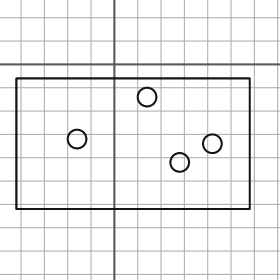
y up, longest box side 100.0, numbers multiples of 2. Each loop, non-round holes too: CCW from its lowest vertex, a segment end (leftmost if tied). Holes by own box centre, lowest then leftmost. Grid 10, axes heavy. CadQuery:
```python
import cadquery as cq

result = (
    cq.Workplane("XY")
    .moveTo(-42.0, -62.0)
    .lineTo(58.0, -62.0)
    .lineTo(58.0, -6.0)
    .lineTo(-42.0, -6.0)
    .close()
    .moveTo(28.0, -42.0)
    .circle(4.0)
    .moveTo(42.0, -34.0)
    .circle(4.0)
    .moveTo(-16.0, -32.0)
    .circle(4.0)
    .moveTo(14.0, -14.0)
    .circle(4.0)
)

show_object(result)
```